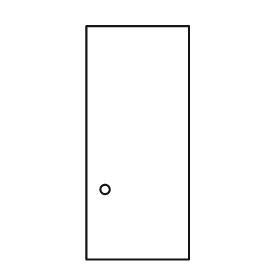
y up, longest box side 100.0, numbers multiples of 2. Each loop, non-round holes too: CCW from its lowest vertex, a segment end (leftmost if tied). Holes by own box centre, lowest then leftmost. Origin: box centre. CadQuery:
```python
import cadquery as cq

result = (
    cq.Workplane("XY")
    .moveTo(-22.0, -50.0)
    .lineTo(22.0, -50.0)
    .lineTo(22.0, 50.0)
    .lineTo(-22.0, 50.0)
    .close()
    .moveTo(-14.0, -20.0)
    .circle(2.0)
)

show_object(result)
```